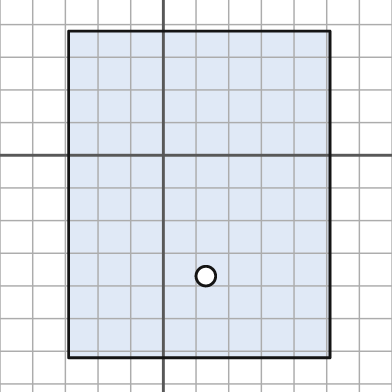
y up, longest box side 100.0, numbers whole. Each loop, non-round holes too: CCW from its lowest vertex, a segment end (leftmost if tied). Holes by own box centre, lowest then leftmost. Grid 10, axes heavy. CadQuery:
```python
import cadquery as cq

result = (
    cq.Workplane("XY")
    .moveTo(-29.0, -62.0)
    .lineTo(51.0, -62.0)
    .lineTo(51.0, 38.0)
    .lineTo(-29.0, 38.0)
    .close()
    .moveTo(13.0, -37.0)
    .circle(3.0)
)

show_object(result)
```